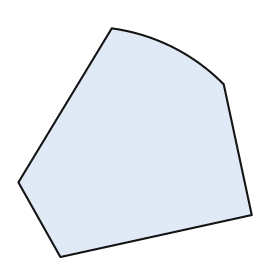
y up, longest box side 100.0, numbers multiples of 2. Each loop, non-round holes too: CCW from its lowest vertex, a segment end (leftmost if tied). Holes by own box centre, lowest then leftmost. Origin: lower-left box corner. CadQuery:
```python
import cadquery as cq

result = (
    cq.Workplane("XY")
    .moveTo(18.0, 0.0)
    .lineTo(100.0, 18.0)
    .lineTo(88.0, 74.0)
    .threePointArc((66.0, 90.0), (40.0, 98.0))
    .lineTo(0.0, 32.0)
    .close()
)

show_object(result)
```